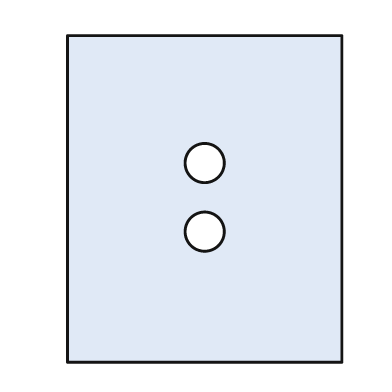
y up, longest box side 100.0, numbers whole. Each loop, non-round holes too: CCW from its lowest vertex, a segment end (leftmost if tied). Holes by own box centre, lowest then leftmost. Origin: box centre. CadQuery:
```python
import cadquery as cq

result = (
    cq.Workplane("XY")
    .moveTo(-42.0, -50.0)
    .lineTo(42.0, -50.0)
    .lineTo(42.0, 50.0)
    .lineTo(-42.0, 50.0)
    .close()
    .moveTo(0.0, -10.0)
    .circle(6.0)
    .moveTo(0.0, 11.0)
    .circle(6.0)
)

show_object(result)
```